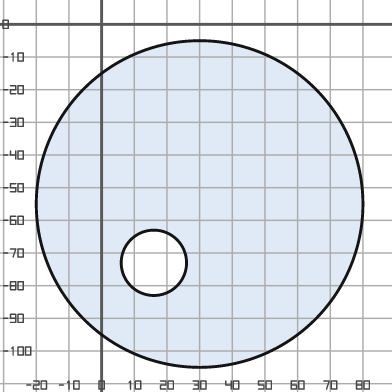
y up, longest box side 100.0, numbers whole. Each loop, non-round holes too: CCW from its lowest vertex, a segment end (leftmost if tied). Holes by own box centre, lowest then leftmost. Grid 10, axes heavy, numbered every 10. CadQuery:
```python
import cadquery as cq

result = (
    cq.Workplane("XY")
    .moveTo(30.0, -55.0)
    .circle(50.0)
    .moveTo(16.0, -73.0)
    .circle(10.0)
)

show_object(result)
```